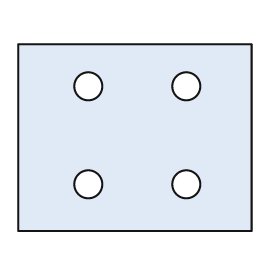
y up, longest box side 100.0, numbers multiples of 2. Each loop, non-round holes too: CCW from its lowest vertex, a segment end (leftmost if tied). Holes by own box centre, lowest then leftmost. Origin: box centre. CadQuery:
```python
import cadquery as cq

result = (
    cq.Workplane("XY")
    .moveTo(-50.0, -40.0)
    .lineTo(50.0, -40.0)
    .lineTo(50.0, 40.0)
    .lineTo(-50.0, 40.0)
    .close()
    .moveTo(-20.0, -20.0)
    .circle(6.0)
    .moveTo(22.0, -20.0)
    .circle(6.0)
    .moveTo(-20.0, 22.0)
    .circle(6.0)
    .moveTo(22.0, 22.0)
    .circle(6.0)
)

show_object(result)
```